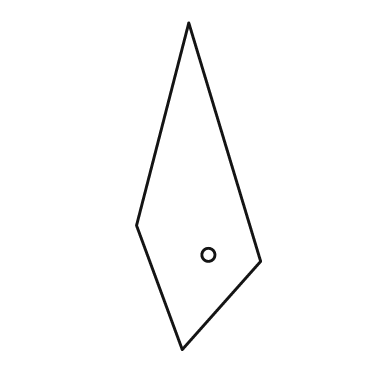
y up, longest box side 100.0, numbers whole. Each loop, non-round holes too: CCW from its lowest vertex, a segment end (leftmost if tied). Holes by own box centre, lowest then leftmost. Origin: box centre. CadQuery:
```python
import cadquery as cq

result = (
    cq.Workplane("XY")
    .moveTo(-5.0, -50.0)
    .lineTo(19.0, -23.0)
    .lineTo(-3.0, 50.0)
    .lineTo(-19.0, -12.0)
    .close()
    .moveTo(3.0, -21.0)
    .circle(2.0)
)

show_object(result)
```